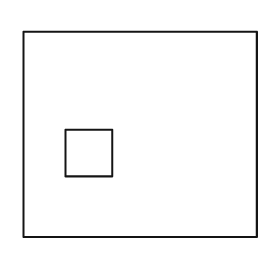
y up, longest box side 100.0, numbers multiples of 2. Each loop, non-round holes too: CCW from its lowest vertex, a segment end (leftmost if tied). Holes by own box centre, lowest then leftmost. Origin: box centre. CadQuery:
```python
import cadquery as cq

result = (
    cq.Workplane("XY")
    .moveTo(-50.0, -44.0)
    .lineTo(50.0, -44.0)
    .lineTo(50.0, 44.0)
    .lineTo(-50.0, 44.0)
    .close()
    .moveTo(-32.0, -18.0)
    .lineTo(-12.0, -18.0)
    .lineTo(-12.0, 2.0)
    .lineTo(-32.0, 2.0)
    .close()
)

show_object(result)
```